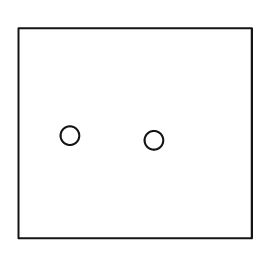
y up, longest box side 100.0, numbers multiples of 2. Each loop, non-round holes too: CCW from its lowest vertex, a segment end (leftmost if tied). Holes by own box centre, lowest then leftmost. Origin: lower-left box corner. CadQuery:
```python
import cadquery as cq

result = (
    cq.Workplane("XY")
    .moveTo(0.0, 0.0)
    .lineTo(100.0, 0.0)
    .lineTo(100.0, 90.0)
    .lineTo(0.0, 90.0)
    .close()
    .moveTo(58.0, 42.0)
    .circle(4.0)
    .moveTo(22.0, 44.0)
    .circle(4.0)
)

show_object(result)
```